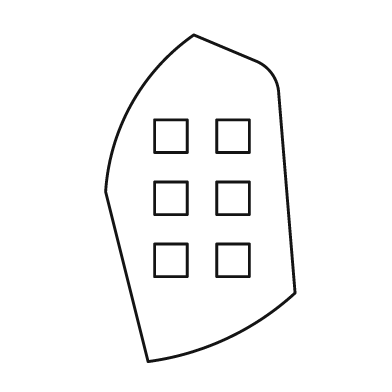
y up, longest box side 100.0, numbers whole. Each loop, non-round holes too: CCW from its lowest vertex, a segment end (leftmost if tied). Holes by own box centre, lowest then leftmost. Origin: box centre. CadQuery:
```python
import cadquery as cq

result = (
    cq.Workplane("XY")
    .moveTo(-16.0, -50.0)
    .threePointArc((8.0, -43.0), (29.0, -29.0))
    .lineTo(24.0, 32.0)
    .threePointArc((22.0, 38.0), (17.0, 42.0))
    .lineTo(-2.0, 50.0)
    .threePointArc((-21.0, 29.0), (-29.0, 2.0))
    .close()
    .moveTo(-14.0, -24.0)
    .lineTo(-4.0, -24.0)
    .lineTo(-4.0, -14.0)
    .lineTo(-14.0, -14.0)
    .close()
    .moveTo(5.0, -24.0)
    .lineTo(15.0, -24.0)
    .lineTo(15.0, -14.0)
    .lineTo(5.0, -14.0)
    .close()
    .moveTo(-14.0, -5.0)
    .lineTo(-4.0, -5.0)
    .lineTo(-4.0, 5.0)
    .lineTo(-14.0, 5.0)
    .close()
    .moveTo(5.0, -5.0)
    .lineTo(15.0, -5.0)
    .lineTo(15.0, 5.0)
    .lineTo(5.0, 5.0)
    .close()
    .moveTo(-14.0, 14.0)
    .lineTo(-4.0, 14.0)
    .lineTo(-4.0, 24.0)
    .lineTo(-14.0, 24.0)
    .close()
    .moveTo(5.0, 14.0)
    .lineTo(15.0, 14.0)
    .lineTo(15.0, 24.0)
    .lineTo(5.0, 24.0)
    .close()
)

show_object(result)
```